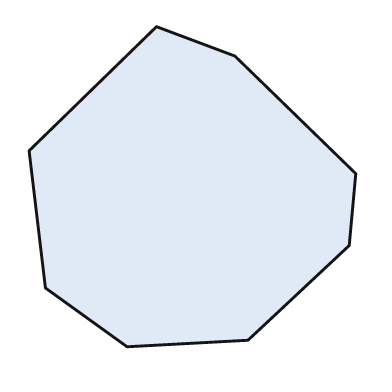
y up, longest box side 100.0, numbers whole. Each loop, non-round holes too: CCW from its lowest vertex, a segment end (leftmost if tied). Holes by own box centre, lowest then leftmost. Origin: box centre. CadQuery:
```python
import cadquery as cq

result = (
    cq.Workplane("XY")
    .moveTo(-20.0, -49.0)
    .lineTo(17.0, -47.0)
    .lineTo(48.0, -18.0)
    .lineTo(50.0, 4.0)
    .lineTo(13.0, 40.0)
    .lineTo(-11.0, 49.0)
    .lineTo(-50.0, 11.0)
    .lineTo(-45.0, -31.0)
    .close()
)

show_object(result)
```